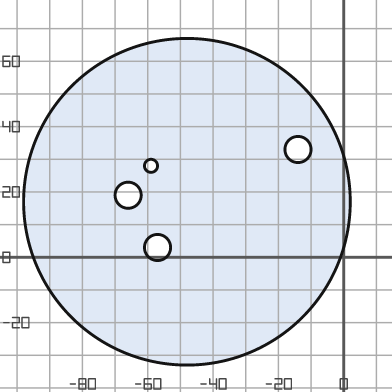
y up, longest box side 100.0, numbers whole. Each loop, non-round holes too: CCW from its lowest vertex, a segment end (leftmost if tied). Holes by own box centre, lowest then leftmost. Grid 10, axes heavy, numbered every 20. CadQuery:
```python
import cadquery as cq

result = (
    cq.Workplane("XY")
    .moveTo(-48.0, 17.0)
    .circle(50.0)
    .moveTo(-57.0, 3.0)
    .circle(4.0)
    .moveTo(-66.0, 19.0)
    .circle(4.0)
    .moveTo(-59.0, 28.0)
    .circle(2.0)
    .moveTo(-14.0, 33.0)
    .circle(4.0)
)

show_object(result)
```